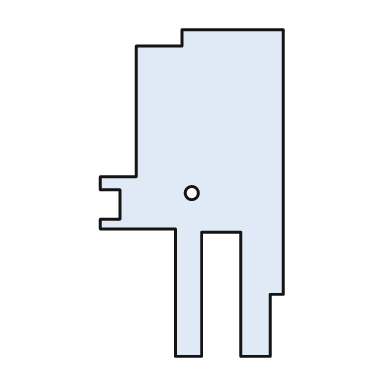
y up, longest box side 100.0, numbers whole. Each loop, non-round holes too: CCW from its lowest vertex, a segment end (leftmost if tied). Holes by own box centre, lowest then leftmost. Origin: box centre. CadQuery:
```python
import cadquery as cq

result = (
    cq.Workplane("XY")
    .moveTo(-5.0, -50.0)
    .lineTo(3.0, -50.0)
    .lineTo(3.0, -12.0)
    .lineTo(15.0, -12.0)
    .lineTo(15.0, -50.0)
    .lineTo(24.0, -50.0)
    .lineTo(24.0, -31.0)
    .lineTo(28.0, -31.0)
    .lineTo(28.0, 50.0)
    .lineTo(-3.0, 50.0)
    .lineTo(-3.0, 45.0)
    .lineTo(-17.0, 45.0)
    .lineTo(-17.0, 5.0)
    .lineTo(-28.0, 5.0)
    .lineTo(-28.0, 1.0)
    .lineTo(-22.0, 1.0)
    .lineTo(-22.0, -8.0)
    .lineTo(-28.0, -8.0)
    .lineTo(-28.0, -11.0)
    .lineTo(-5.0, -11.0)
    .close()
    .moveTo(0.0, 0.0)
    .circle(2.0)
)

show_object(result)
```